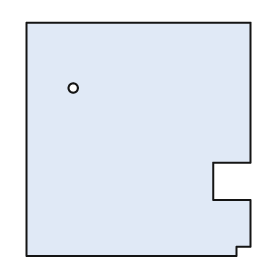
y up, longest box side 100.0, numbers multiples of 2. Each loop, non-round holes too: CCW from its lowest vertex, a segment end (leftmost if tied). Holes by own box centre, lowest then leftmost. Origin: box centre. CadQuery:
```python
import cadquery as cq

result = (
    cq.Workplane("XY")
    .moveTo(-48.0, -50.0)
    .lineTo(42.0, -50.0)
    .lineTo(42.0, -46.0)
    .lineTo(48.0, -46.0)
    .lineTo(48.0, -26.0)
    .lineTo(32.0, -26.0)
    .lineTo(32.0, -10.0)
    .lineTo(48.0, -10.0)
    .lineTo(48.0, 50.0)
    .lineTo(-48.0, 50.0)
    .close()
    .moveTo(-28.0, 22.0)
    .circle(2.0)
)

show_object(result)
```